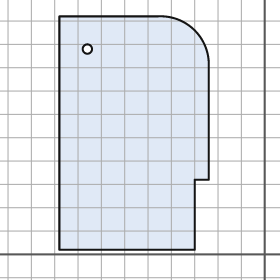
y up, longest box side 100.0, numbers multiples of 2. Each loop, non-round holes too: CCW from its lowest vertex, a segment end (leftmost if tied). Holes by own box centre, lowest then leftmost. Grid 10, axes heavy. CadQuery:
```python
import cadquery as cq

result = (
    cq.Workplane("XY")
    .moveTo(-88.0, 2.0)
    .lineTo(-30.0, 2.0)
    .lineTo(-30.0, 32.0)
    .lineTo(-24.0, 32.0)
    .lineTo(-24.0, 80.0)
    .threePointArc((-30.0, 96.0), (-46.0, 102.0))
    .lineTo(-88.0, 102.0)
    .close()
    .moveTo(-76.0, 88.0)
    .circle(2.0)
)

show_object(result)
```